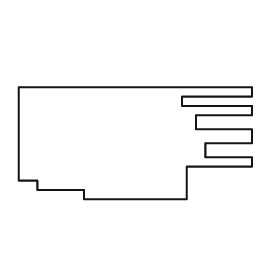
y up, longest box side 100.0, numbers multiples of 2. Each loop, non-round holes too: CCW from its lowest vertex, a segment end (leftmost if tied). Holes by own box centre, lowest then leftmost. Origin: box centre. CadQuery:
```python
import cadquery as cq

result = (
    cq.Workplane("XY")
    .moveTo(-22.0, -24.0)
    .lineTo(22.0, -24.0)
    .lineTo(22.0, -10.0)
    .lineTo(50.0, -10.0)
    .lineTo(50.0, -6.0)
    .lineTo(30.0, -6.0)
    .lineTo(30.0, 0.0)
    .lineTo(50.0, 0.0)
    .lineTo(50.0, 6.0)
    .lineTo(26.0, 6.0)
    .lineTo(26.0, 12.0)
    .lineTo(50.0, 12.0)
    .lineTo(50.0, 16.0)
    .lineTo(20.0, 16.0)
    .lineTo(20.0, 20.0)
    .lineTo(50.0, 20.0)
    .lineTo(50.0, 24.0)
    .lineTo(-50.0, 24.0)
    .lineTo(-50.0, -16.0)
    .lineTo(-42.0, -16.0)
    .lineTo(-42.0, -20.0)
    .lineTo(-22.0, -20.0)
    .close()
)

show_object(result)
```